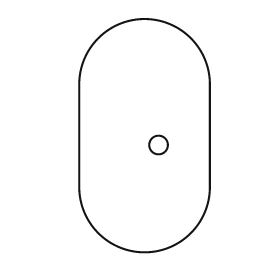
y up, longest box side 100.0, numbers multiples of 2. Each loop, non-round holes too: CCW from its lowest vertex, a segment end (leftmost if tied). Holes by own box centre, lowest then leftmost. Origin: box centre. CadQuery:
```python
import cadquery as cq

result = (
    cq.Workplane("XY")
    .moveTo(-28.0, -22.0)
    .threePointArc((0.0, -50.0), (28.0, -22.0))
    .lineTo(28.0, 22.0)
    .threePointArc((0.0, 50.0), (-28.0, 22.0))
    .close()
    .moveTo(6.0, -4.0)
    .circle(4.0)
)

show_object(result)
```